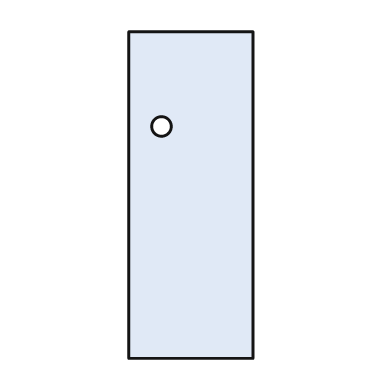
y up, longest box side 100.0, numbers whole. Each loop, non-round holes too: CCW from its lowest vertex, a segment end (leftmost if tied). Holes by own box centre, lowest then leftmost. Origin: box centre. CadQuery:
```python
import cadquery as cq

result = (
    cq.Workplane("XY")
    .moveTo(-19.0, -50.0)
    .lineTo(19.0, -50.0)
    .lineTo(19.0, 50.0)
    .lineTo(-19.0, 50.0)
    .close()
    .moveTo(-9.0, 21.0)
    .circle(3.0)
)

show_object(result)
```